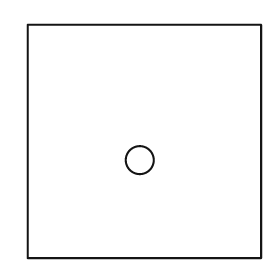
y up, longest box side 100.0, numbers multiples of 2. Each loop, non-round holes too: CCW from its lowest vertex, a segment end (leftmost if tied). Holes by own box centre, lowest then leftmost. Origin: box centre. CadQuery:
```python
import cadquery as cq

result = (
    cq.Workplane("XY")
    .moveTo(-50.0, -50.0)
    .lineTo(50.0, -50.0)
    .lineTo(50.0, 50.0)
    .lineTo(-50.0, 50.0)
    .close()
    .moveTo(-2.0, -8.0)
    .circle(6.0)
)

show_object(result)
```